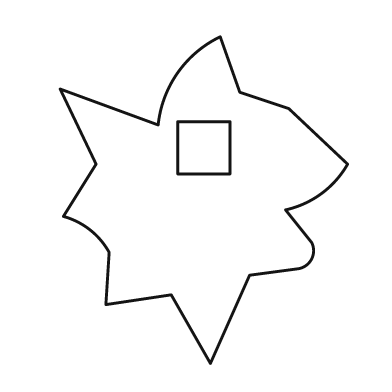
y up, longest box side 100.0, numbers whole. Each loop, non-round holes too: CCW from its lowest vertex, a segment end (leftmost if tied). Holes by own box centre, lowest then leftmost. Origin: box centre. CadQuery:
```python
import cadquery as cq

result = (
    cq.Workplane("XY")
    .moveTo(2.0, -50.0)
    .lineTo(14.0, -23.0)
    .lineTo(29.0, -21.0)
    .threePointArc((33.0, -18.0), (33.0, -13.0))
    .lineTo(25.0, -3.0)
    .threePointArc((36.0, 2.0), (44.0, 11.0))
    .lineTo(26.0, 28.0)
    .lineTo(11.0, 33.0)
    .lineTo(5.0, 50.0)
    .threePointArc((-8.0, 39.0), (-14.0, 23.0))
    .lineTo(-44.0, 34.0)
    .lineTo(-33.0, 11.0)
    .lineTo(-43.0, -5.0)
    .threePointArc((-35.0, -9.0), (-29.0, -16.0))
    .lineTo(-30.0, -32.0)
    .lineTo(-10.0, -29.0)
    .close()
    .moveTo(-8.0, 8.0)
    .lineTo(8.0, 8.0)
    .lineTo(8.0, 24.0)
    .lineTo(-8.0, 24.0)
    .close()
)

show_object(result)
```